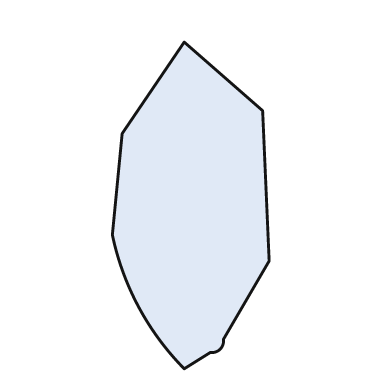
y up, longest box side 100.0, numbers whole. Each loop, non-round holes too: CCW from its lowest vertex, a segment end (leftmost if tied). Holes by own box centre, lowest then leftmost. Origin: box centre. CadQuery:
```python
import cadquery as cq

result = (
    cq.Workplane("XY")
    .moveTo(-2.0, -50.0)
    .lineTo(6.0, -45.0)
    .threePointArc((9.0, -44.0), (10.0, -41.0))
    .lineTo(24.0, -17.0)
    .lineTo(22.0, 29.0)
    .lineTo(-2.0, 50.0)
    .lineTo(-21.0, 22.0)
    .lineTo(-24.0, -9.0)
    .threePointArc((-16.0, -31.0), (-2.0, -50.0))
    .close()
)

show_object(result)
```